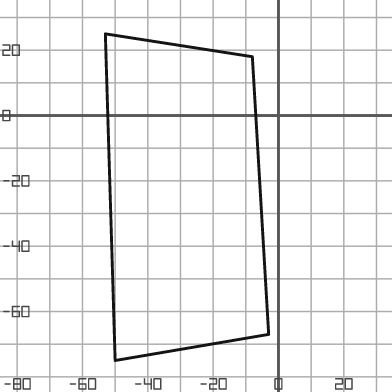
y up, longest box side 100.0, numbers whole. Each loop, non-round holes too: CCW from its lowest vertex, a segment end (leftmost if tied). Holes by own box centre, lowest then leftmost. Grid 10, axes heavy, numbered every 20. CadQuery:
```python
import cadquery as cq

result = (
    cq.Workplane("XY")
    .moveTo(-50.0, -75.0)
    .lineTo(-3.0, -67.0)
    .lineTo(-8.0, 18.0)
    .lineTo(-53.0, 25.0)
    .close()
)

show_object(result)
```